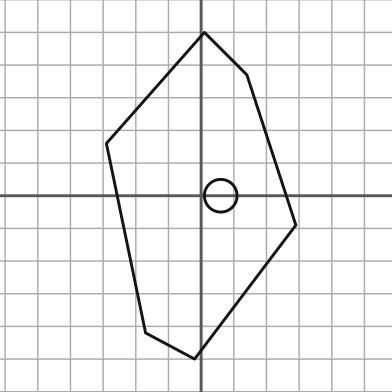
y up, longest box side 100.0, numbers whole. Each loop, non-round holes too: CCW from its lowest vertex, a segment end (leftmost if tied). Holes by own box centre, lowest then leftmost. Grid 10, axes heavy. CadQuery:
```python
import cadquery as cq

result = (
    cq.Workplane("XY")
    .moveTo(-2.0, -50.0)
    .lineTo(29.0, -9.0)
    .lineTo(14.0, 37.0)
    .lineTo(1.0, 50.0)
    .lineTo(-29.0, 16.0)
    .lineTo(-17.0, -42.0)
    .close()
    .moveTo(6.0, 0.0)
    .circle(5.0)
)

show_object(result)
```